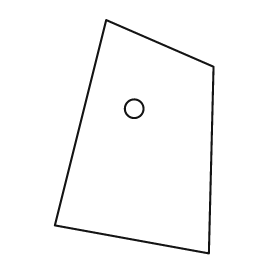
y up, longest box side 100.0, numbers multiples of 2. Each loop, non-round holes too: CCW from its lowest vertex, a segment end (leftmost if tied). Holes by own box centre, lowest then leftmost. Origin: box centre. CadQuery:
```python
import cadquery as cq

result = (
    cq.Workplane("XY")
    .moveTo(32.0, -50.0)
    .lineTo(34.0, 30.0)
    .lineTo(-12.0, 50.0)
    .lineTo(-34.0, -38.0)
    .close()
    .moveTo(0.0, 12.0)
    .circle(4.0)
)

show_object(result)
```